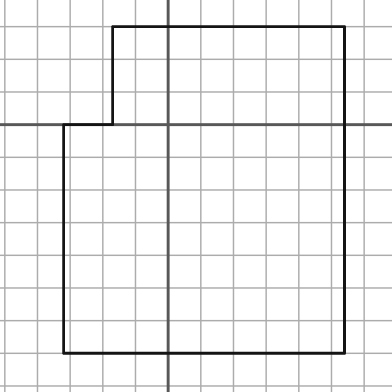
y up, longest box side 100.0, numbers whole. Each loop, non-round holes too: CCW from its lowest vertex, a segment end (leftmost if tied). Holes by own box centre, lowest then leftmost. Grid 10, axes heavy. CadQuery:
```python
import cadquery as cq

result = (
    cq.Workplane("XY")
    .moveTo(-32.0, -70.0)
    .lineTo(54.0, -70.0)
    .lineTo(54.0, 30.0)
    .lineTo(-17.0, 30.0)
    .lineTo(-17.0, 0.0)
    .lineTo(-32.0, 0.0)
    .close()
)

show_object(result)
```